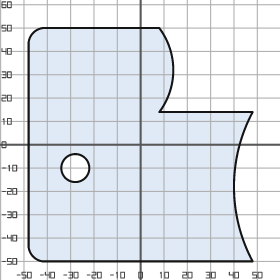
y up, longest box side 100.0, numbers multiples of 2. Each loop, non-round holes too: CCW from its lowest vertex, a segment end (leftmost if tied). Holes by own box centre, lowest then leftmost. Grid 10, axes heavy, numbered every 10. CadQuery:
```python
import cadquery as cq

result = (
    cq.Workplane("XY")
    .moveTo(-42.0, -50.0)
    .lineTo(48.0, -50.0)
    .threePointArc((40.0, -18.0), (48.0, 14.0))
    .lineTo(8.0, 14.0)
    .threePointArc((14.0, 32.0), (8.0, 50.0))
    .lineTo(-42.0, 50.0)
    .threePointArc((-46.0, 48.0), (-48.0, 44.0))
    .lineTo(-48.0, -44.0)
    .threePointArc((-46.0, -48.0), (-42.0, -50.0))
    .close()
    .moveTo(-28.0, -10.0)
    .circle(6.0)
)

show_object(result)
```